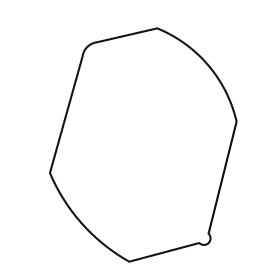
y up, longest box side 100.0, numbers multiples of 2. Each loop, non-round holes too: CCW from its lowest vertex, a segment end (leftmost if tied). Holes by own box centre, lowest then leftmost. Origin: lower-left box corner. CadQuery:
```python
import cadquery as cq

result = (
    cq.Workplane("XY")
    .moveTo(34.0, 0.0)
    .lineTo(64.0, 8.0)
    .threePointArc((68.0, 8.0), (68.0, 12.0))
    .lineTo(80.0, 60.0)
    .threePointArc((68.0, 84.0), (46.0, 100.0))
    .lineTo(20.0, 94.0)
    .threePointArc((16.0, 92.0), (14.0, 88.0))
    .lineTo(0.0, 38.0)
    .threePointArc((14.0, 16.0), (34.0, 0.0))
    .close()
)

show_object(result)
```